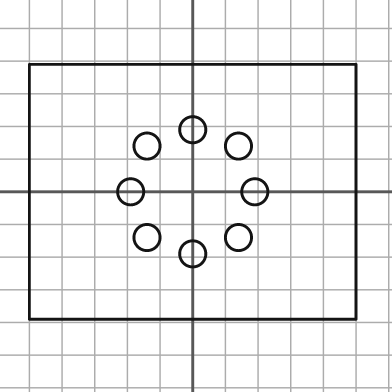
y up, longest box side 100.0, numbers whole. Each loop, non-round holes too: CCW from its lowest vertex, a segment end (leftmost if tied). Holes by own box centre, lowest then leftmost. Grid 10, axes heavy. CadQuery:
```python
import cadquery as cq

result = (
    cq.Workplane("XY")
    .moveTo(-50.0, -39.0)
    .lineTo(50.0, -39.0)
    .lineTo(50.0, 39.0)
    .lineTo(-50.0, 39.0)
    .close()
    .moveTo(0.0, -19.0)
    .circle(4.0)
    .moveTo(-14.0, -14.0)
    .circle(4.0)
    .moveTo(14.0, -14.0)
    .circle(4.0)
    .moveTo(-19.0, 0.0)
    .circle(4.0)
    .moveTo(19.0, 0.0)
    .circle(4.0)
    .moveTo(-14.0, 14.0)
    .circle(4.0)
    .moveTo(14.0, 14.0)
    .circle(4.0)
    .moveTo(0.0, 19.0)
    .circle(4.0)
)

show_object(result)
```